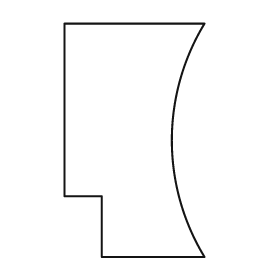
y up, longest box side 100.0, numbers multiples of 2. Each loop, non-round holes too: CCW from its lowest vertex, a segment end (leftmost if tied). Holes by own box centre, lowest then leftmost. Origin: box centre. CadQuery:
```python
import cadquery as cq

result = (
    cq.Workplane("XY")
    .moveTo(-14.0, -50.0)
    .lineTo(30.0, -50.0)
    .threePointArc((16.0, 0.0), (30.0, 50.0))
    .lineTo(-30.0, 50.0)
    .lineTo(-30.0, -24.0)
    .lineTo(-14.0, -24.0)
    .close()
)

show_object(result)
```